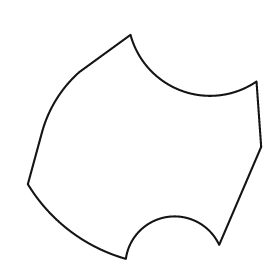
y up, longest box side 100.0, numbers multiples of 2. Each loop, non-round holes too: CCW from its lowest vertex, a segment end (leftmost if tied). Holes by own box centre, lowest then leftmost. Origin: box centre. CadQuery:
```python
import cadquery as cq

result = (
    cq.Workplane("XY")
    .moveTo(-8.0, -48.0)
    .threePointArc((10.0, -30.0), (32.0, -42.0))
    .lineTo(50.0, 0.0)
    .lineTo(48.0, 28.0)
    .threePointArc((16.0, 24.0), (-6.0, 48.0))
    .lineTo(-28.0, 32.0)
    .threePointArc((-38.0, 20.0), (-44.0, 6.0))
    .lineTo(-50.0, -16.0)
    .threePointArc((-32.0, -36.0), (-8.0, -48.0))
    .close()
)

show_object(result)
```